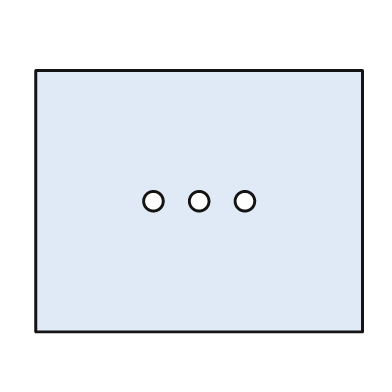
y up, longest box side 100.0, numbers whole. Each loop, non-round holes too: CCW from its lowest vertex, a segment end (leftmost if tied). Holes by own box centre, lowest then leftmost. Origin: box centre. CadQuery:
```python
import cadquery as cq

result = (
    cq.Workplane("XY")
    .moveTo(-50.0, -40.0)
    .lineTo(50.0, -40.0)
    .lineTo(50.0, 40.0)
    .lineTo(-50.0, 40.0)
    .close()
    .moveTo(-14.0, 0.0)
    .circle(3.0)
    .moveTo(0.0, 0.0)
    .circle(3.0)
    .moveTo(14.0, 0.0)
    .circle(3.0)
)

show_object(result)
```